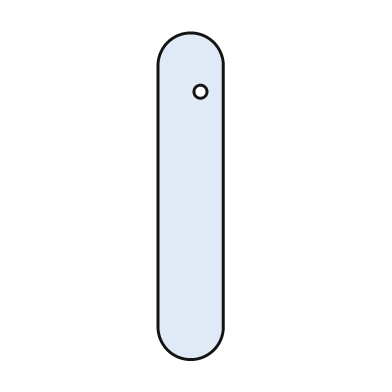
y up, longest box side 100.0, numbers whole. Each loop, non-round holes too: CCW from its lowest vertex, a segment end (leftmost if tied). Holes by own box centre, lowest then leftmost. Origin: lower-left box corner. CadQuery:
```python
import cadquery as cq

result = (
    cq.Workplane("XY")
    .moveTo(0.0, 10.0)
    .threePointArc((10.0, 0.0), (20.0, 10.0))
    .lineTo(20.0, 90.0)
    .threePointArc((10.0, 100.0), (0.0, 90.0))
    .close()
    .moveTo(13.0, 82.0)
    .circle(2.0)
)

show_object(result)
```